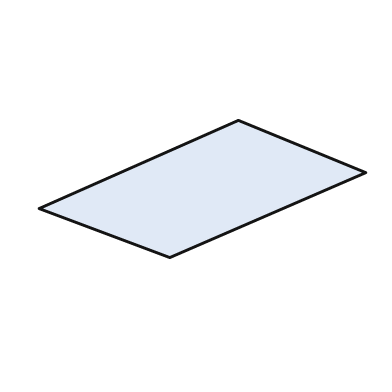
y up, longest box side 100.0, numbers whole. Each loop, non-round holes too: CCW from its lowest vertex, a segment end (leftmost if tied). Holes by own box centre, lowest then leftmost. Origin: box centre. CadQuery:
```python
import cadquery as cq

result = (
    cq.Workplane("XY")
    .moveTo(-10.0, -21.0)
    .lineTo(50.0, 5.0)
    .lineTo(11.0, 21.0)
    .lineTo(-50.0, -6.0)
    .close()
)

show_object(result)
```